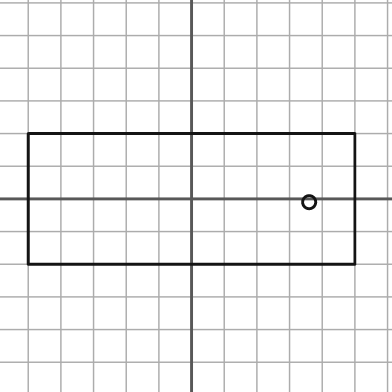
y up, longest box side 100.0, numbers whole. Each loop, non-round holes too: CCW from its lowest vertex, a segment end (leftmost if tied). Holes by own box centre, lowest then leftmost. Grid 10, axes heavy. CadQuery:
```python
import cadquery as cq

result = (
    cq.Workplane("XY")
    .moveTo(-50.0, -20.0)
    .lineTo(50.0, -20.0)
    .lineTo(50.0, 20.0)
    .lineTo(-50.0, 20.0)
    .close()
    .moveTo(36.0, -1.0)
    .circle(2.0)
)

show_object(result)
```